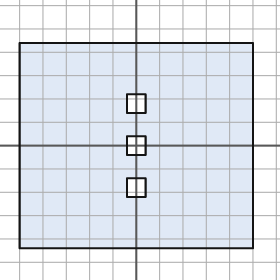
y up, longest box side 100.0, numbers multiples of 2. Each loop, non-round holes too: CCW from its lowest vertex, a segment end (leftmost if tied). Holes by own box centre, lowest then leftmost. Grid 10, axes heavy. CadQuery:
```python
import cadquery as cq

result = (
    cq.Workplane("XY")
    .moveTo(-50.0, -44.0)
    .lineTo(50.0, -44.0)
    .lineTo(50.0, 44.0)
    .lineTo(-50.0, 44.0)
    .close()
    .moveTo(-4.0, -22.0)
    .lineTo(4.0, -22.0)
    .lineTo(4.0, -14.0)
    .lineTo(-4.0, -14.0)
    .close()
    .moveTo(-4.0, -4.0)
    .lineTo(4.0, -4.0)
    .lineTo(4.0, 4.0)
    .lineTo(-4.0, 4.0)
    .close()
    .moveTo(-4.0, 14.0)
    .lineTo(4.0, 14.0)
    .lineTo(4.0, 22.0)
    .lineTo(-4.0, 22.0)
    .close()
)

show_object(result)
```